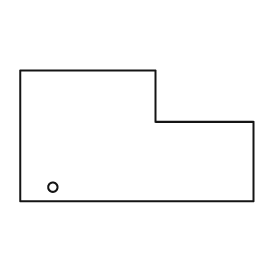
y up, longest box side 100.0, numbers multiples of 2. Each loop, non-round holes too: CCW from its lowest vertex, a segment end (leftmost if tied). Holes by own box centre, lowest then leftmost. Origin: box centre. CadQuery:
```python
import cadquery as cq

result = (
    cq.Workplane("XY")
    .moveTo(-50.0, -28.0)
    .lineTo(50.0, -28.0)
    .lineTo(50.0, 6.0)
    .lineTo(8.0, 6.0)
    .lineTo(8.0, 28.0)
    .lineTo(-50.0, 28.0)
    .close()
    .moveTo(-36.0, -22.0)
    .circle(2.0)
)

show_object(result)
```